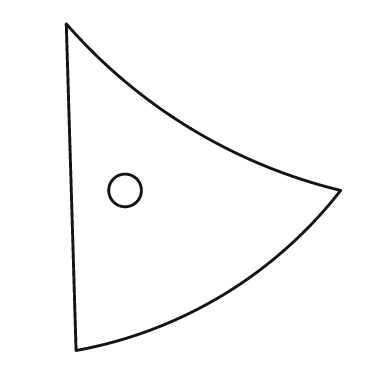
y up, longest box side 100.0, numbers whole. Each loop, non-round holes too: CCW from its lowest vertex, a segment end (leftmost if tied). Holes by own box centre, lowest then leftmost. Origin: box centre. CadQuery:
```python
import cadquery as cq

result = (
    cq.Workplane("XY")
    .moveTo(-39.0, -50.0)
    .threePointArc((6.0, -33.0), (42.0, -1.0))
    .threePointArc((-4.0, 18.0), (-42.0, 50.0))
    .close()
    .moveTo(-24.0, -1.0)
    .circle(5.0)
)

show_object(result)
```